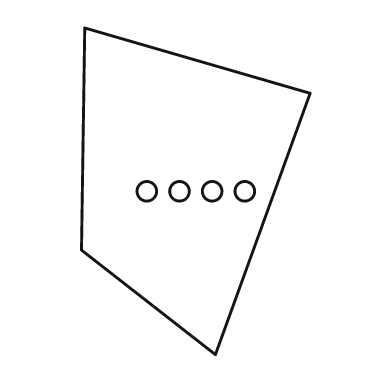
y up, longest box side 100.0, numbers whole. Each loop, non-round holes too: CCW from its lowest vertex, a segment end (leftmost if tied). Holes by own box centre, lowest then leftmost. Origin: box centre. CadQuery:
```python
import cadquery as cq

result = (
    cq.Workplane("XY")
    .moveTo(6.0, -50.0)
    .lineTo(35.0, 30.0)
    .lineTo(-34.0, 50.0)
    .lineTo(-35.0, -18.0)
    .close()
    .moveTo(-15.0, 0.0)
    .circle(3.0)
    .moveTo(-5.0, 0.0)
    .circle(3.0)
    .moveTo(5.0, 0.0)
    .circle(3.0)
    .moveTo(15.0, 0.0)
    .circle(3.0)
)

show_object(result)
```